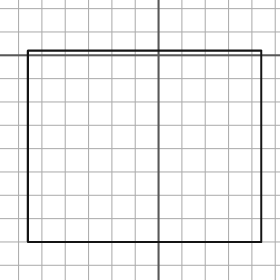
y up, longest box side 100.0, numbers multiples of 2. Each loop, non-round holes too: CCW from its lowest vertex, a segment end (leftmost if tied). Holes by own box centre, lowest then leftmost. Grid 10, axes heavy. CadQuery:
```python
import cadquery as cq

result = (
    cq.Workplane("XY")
    .moveTo(-56.0, -80.0)
    .lineTo(44.0, -80.0)
    .lineTo(44.0, 2.0)
    .lineTo(-56.0, 2.0)
    .close()
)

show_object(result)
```